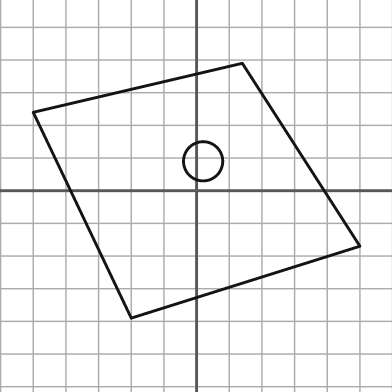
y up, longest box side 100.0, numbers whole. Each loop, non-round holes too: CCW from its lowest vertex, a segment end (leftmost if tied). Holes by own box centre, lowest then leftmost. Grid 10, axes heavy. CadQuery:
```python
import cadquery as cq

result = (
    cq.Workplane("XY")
    .moveTo(-20.0, -39.0)
    .lineTo(50.0, -17.0)
    .lineTo(14.0, 39.0)
    .lineTo(-50.0, 24.0)
    .close()
    .moveTo(2.0, 9.0)
    .circle(6.0)
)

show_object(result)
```